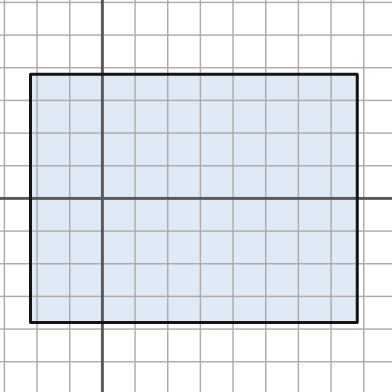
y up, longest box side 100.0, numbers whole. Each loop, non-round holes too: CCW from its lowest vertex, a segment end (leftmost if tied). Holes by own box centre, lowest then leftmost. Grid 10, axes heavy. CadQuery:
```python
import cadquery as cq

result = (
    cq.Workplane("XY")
    .moveTo(-22.0, -38.0)
    .lineTo(78.0, -38.0)
    .lineTo(78.0, 38.0)
    .lineTo(-22.0, 38.0)
    .close()
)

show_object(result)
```